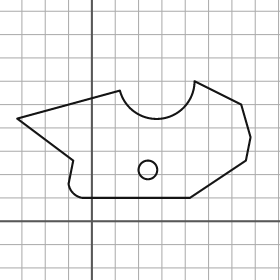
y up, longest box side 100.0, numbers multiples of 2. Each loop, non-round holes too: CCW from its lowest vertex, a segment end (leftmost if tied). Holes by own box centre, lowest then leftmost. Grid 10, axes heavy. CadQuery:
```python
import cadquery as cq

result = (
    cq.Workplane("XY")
    .moveTo(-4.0, 10.0)
    .lineTo(42.0, 10.0)
    .lineTo(66.0, 26.0)
    .lineTo(68.0, 36.0)
    .lineTo(64.0, 50.0)
    .lineTo(44.0, 60.0)
    .threePointArc((30.0, 44.0), (12.0, 56.0))
    .lineTo(-32.0, 44.0)
    .lineTo(-8.0, 26.0)
    .lineTo(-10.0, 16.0)
    .threePointArc((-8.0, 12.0), (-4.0, 10.0))
    .close()
    .moveTo(24.0, 22.0)
    .circle(4.0)
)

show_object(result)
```